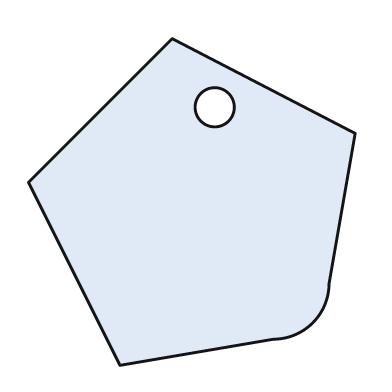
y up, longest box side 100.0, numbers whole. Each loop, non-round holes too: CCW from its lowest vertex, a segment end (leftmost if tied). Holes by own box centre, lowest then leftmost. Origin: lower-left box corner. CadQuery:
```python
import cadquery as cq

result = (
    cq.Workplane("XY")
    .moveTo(28.0, 0.0)
    .lineTo(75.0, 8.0)
    .threePointArc((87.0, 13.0), (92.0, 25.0))
    .lineTo(100.0, 71.0)
    .lineTo(44.0, 100.0)
    .lineTo(0.0, 56.0)
    .close()
    .moveTo(57.0, 79.0)
    .circle(6.0)
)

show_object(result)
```